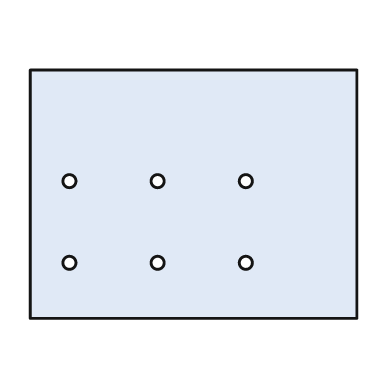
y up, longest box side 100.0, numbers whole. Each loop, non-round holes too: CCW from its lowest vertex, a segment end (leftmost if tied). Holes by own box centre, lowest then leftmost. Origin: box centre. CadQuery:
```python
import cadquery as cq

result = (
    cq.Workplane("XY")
    .moveTo(-50.0, -38.0)
    .lineTo(50.0, -38.0)
    .lineTo(50.0, 38.0)
    .lineTo(-50.0, 38.0)
    .close()
    .moveTo(-38.0, -21.0)
    .circle(2.0)
    .moveTo(-11.0, -21.0)
    .circle(2.0)
    .moveTo(16.0, -21.0)
    .circle(2.0)
    .moveTo(-38.0, 4.0)
    .circle(2.0)
    .moveTo(-11.0, 4.0)
    .circle(2.0)
    .moveTo(16.0, 4.0)
    .circle(2.0)
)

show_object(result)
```